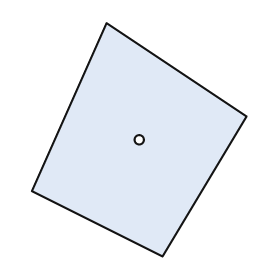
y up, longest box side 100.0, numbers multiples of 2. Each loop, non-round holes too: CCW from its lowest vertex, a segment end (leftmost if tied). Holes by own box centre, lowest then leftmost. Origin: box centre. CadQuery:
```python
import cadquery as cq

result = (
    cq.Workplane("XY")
    .moveTo(10.0, -50.0)
    .lineTo(46.0, 10.0)
    .lineTo(-14.0, 50.0)
    .lineTo(-46.0, -22.0)
    .close()
    .moveTo(0.0, 0.0)
    .circle(2.0)
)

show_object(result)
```